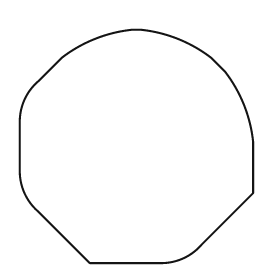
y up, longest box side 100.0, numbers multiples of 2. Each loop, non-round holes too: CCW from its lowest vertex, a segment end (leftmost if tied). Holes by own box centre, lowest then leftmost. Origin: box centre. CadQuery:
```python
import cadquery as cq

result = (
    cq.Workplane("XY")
    .moveTo(-20.0, -50.0)
    .lineTo(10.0, -50.0)
    .threePointArc((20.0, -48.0), (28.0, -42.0))
    .lineTo(50.0, -20.0)
    .lineTo(50.0, 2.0)
    .threePointArc((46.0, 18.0), (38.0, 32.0))
    .lineTo(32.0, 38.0)
    .threePointArc((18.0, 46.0), (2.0, 50.0))
    .lineTo(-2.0, 50.0)
    .threePointArc((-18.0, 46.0), (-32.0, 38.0))
    .lineTo(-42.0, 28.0)
    .threePointArc((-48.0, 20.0), (-50.0, 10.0))
    .lineTo(-50.0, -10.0)
    .threePointArc((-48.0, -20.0), (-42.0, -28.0))
    .close()
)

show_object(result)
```